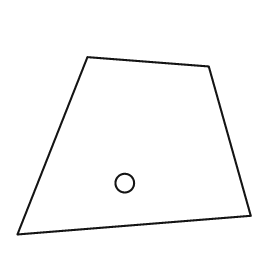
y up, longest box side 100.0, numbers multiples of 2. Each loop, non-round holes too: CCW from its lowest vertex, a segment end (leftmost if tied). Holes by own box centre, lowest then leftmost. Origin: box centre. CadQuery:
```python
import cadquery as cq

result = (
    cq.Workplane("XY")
    .moveTo(-50.0, -38.0)
    .lineTo(50.0, -30.0)
    .lineTo(32.0, 34.0)
    .lineTo(-20.0, 38.0)
    .close()
    .moveTo(-4.0, -16.0)
    .circle(4.0)
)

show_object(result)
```